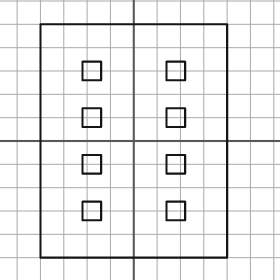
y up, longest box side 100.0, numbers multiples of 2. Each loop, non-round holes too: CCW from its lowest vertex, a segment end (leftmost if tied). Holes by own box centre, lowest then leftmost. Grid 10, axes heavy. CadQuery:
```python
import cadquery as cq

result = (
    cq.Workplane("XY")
    .moveTo(-40.0, -50.0)
    .lineTo(40.0, -50.0)
    .lineTo(40.0, 50.0)
    .lineTo(-40.0, 50.0)
    .close()
    .moveTo(-22.0, -34.0)
    .lineTo(-14.0, -34.0)
    .lineTo(-14.0, -26.0)
    .lineTo(-22.0, -26.0)
    .close()
    .moveTo(14.0, -34.0)
    .lineTo(22.0, -34.0)
    .lineTo(22.0, -26.0)
    .lineTo(14.0, -26.0)
    .close()
    .moveTo(-22.0, -14.0)
    .lineTo(-14.0, -14.0)
    .lineTo(-14.0, -6.0)
    .lineTo(-22.0, -6.0)
    .close()
    .moveTo(14.0, -14.0)
    .lineTo(22.0, -14.0)
    .lineTo(22.0, -6.0)
    .lineTo(14.0, -6.0)
    .close()
    .moveTo(-22.0, 6.0)
    .lineTo(-14.0, 6.0)
    .lineTo(-14.0, 14.0)
    .lineTo(-22.0, 14.0)
    .close()
    .moveTo(14.0, 6.0)
    .lineTo(22.0, 6.0)
    .lineTo(22.0, 14.0)
    .lineTo(14.0, 14.0)
    .close()
    .moveTo(-22.0, 26.0)
    .lineTo(-14.0, 26.0)
    .lineTo(-14.0, 34.0)
    .lineTo(-22.0, 34.0)
    .close()
    .moveTo(14.0, 26.0)
    .lineTo(22.0, 26.0)
    .lineTo(22.0, 34.0)
    .lineTo(14.0, 34.0)
    .close()
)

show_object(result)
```